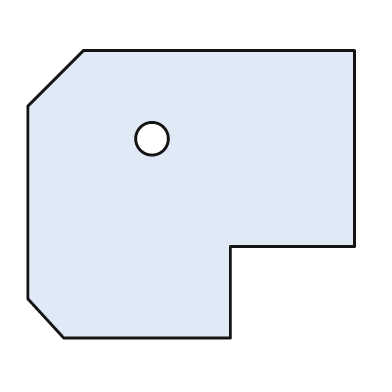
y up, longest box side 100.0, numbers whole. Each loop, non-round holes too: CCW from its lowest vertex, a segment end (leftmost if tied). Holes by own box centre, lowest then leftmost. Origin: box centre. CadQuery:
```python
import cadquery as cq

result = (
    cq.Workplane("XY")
    .moveTo(-39.0, -44.0)
    .lineTo(12.0, -44.0)
    .lineTo(12.0, -16.0)
    .lineTo(50.0, -16.0)
    .lineTo(50.0, 44.0)
    .lineTo(-33.0, 44.0)
    .lineTo(-50.0, 27.0)
    .lineTo(-50.0, -32.0)
    .close()
    .moveTo(-12.0, 17.0)
    .circle(5.0)
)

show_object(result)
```